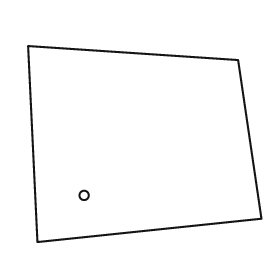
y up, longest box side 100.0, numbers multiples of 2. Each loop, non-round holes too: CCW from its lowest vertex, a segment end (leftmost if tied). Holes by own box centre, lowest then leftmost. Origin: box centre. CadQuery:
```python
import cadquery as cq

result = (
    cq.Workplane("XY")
    .moveTo(-46.0, -42.0)
    .lineTo(50.0, -32.0)
    .lineTo(40.0, 36.0)
    .lineTo(-50.0, 42.0)
    .close()
    .moveTo(-26.0, -22.0)
    .circle(2.0)
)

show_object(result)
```